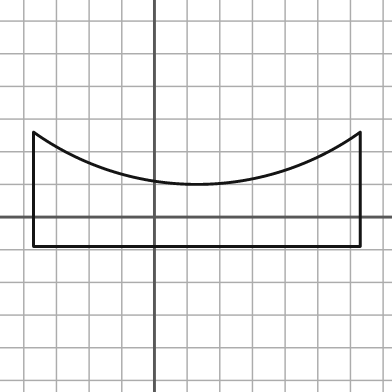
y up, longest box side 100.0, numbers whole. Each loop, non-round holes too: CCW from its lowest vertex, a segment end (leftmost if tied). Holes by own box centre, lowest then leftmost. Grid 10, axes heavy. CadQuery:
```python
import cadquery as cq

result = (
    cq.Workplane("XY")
    .moveTo(-37.0, -9.0)
    .lineTo(63.0, -9.0)
    .lineTo(63.0, 26.0)
    .threePointArc((13.0, 10.0), (-37.0, 26.0))
    .close()
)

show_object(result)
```